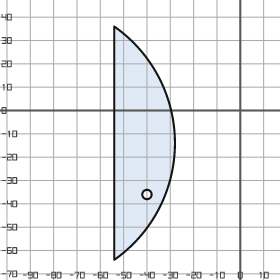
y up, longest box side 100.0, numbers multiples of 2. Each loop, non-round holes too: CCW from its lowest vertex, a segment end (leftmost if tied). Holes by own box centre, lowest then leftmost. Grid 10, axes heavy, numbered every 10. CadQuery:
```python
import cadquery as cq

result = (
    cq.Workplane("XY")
    .moveTo(-54.0, -64.0)
    .threePointArc((-28.0, -14.0), (-54.0, 36.0))
    .close()
    .moveTo(-40.0, -36.0)
    .circle(2.0)
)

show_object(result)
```